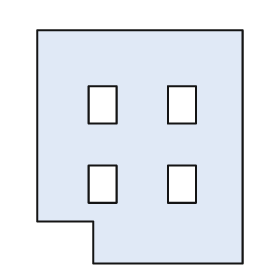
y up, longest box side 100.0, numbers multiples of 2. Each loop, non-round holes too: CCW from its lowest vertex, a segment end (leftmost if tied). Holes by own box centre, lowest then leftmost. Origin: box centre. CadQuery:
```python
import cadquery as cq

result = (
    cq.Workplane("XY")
    .moveTo(-20.0, -50.0)
    .lineTo(44.0, -50.0)
    .lineTo(44.0, 50.0)
    .lineTo(-44.0, 50.0)
    .lineTo(-44.0, -32.0)
    .lineTo(-20.0, -32.0)
    .close()
    .moveTo(-22.0, -24.0)
    .lineTo(-10.0, -24.0)
    .lineTo(-10.0, -8.0)
    .lineTo(-22.0, -8.0)
    .close()
    .moveTo(12.0, -24.0)
    .lineTo(24.0, -24.0)
    .lineTo(24.0, -8.0)
    .lineTo(12.0, -8.0)
    .close()
    .moveTo(-22.0, 10.0)
    .lineTo(-10.0, 10.0)
    .lineTo(-10.0, 26.0)
    .lineTo(-22.0, 26.0)
    .close()
    .moveTo(12.0, 10.0)
    .lineTo(24.0, 10.0)
    .lineTo(24.0, 26.0)
    .lineTo(12.0, 26.0)
    .close()
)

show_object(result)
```